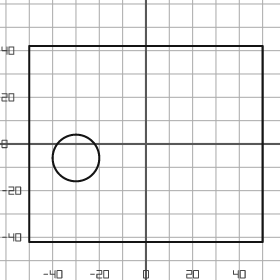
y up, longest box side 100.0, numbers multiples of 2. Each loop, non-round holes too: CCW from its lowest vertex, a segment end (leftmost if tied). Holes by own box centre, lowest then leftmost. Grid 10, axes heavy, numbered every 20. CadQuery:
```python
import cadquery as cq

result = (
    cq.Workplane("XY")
    .moveTo(-50.0, -42.0)
    .lineTo(50.0, -42.0)
    .lineTo(50.0, 42.0)
    .lineTo(-50.0, 42.0)
    .close()
    .moveTo(-30.0, -6.0)
    .circle(10.0)
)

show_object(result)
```